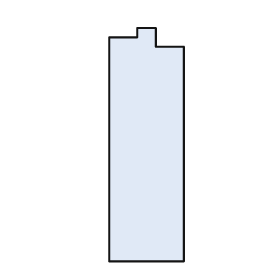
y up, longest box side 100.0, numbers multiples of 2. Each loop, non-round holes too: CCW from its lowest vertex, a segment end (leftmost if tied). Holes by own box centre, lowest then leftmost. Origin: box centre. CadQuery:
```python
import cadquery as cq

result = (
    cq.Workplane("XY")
    .moveTo(-16.0, -50.0)
    .lineTo(16.0, -50.0)
    .lineTo(16.0, 42.0)
    .lineTo(4.0, 42.0)
    .lineTo(4.0, 50.0)
    .lineTo(-4.0, 50.0)
    .lineTo(-4.0, 46.0)
    .lineTo(-16.0, 46.0)
    .close()
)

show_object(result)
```